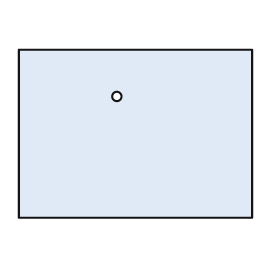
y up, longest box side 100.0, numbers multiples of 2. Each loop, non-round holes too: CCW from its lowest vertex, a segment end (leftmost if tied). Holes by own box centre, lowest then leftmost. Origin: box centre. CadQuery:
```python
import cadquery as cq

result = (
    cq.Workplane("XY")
    .moveTo(-50.0, -36.0)
    .lineTo(50.0, -36.0)
    .lineTo(50.0, 36.0)
    .lineTo(-50.0, 36.0)
    .close()
    .moveTo(-8.0, 16.0)
    .circle(2.0)
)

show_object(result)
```